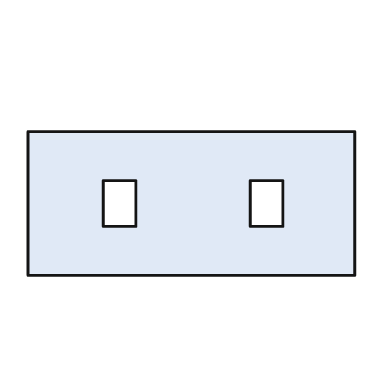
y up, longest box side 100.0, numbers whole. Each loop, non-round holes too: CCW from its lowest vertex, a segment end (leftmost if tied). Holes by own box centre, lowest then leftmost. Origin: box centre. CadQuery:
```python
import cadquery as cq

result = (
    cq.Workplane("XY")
    .moveTo(-50.0, -22.0)
    .lineTo(50.0, -22.0)
    .lineTo(50.0, 22.0)
    .lineTo(-50.0, 22.0)
    .close()
    .moveTo(-27.0, -7.0)
    .lineTo(-17.0, -7.0)
    .lineTo(-17.0, 7.0)
    .lineTo(-27.0, 7.0)
    .close()
    .moveTo(18.0, -7.0)
    .lineTo(28.0, -7.0)
    .lineTo(28.0, 7.0)
    .lineTo(18.0, 7.0)
    .close()
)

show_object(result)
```